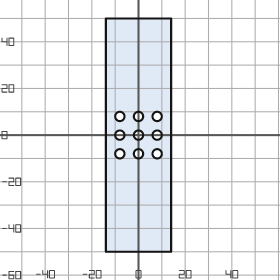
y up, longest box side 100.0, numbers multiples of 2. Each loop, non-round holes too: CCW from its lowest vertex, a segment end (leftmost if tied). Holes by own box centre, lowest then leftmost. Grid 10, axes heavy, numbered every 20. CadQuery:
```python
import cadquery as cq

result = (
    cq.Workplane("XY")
    .moveTo(-14.0, -50.0)
    .lineTo(14.0, -50.0)
    .lineTo(14.0, 50.0)
    .lineTo(-14.0, 50.0)
    .close()
    .moveTo(-8.0, -8.0)
    .circle(2.0)
    .moveTo(0.0, -8.0)
    .circle(2.0)
    .moveTo(8.0, -8.0)
    .circle(2.0)
    .moveTo(-8.0, 0.0)
    .circle(2.0)
    .moveTo(0.0, 0.0)
    .circle(2.0)
    .moveTo(8.0, 0.0)
    .circle(2.0)
    .moveTo(-8.0, 8.0)
    .circle(2.0)
    .moveTo(0.0, 8.0)
    .circle(2.0)
    .moveTo(8.0, 8.0)
    .circle(2.0)
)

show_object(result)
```